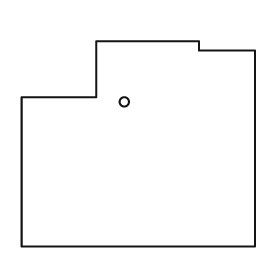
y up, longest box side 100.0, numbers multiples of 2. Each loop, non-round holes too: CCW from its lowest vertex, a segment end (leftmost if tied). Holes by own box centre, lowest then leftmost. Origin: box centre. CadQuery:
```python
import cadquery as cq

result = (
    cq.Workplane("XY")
    .moveTo(-50.0, -44.0)
    .lineTo(50.0, -44.0)
    .lineTo(50.0, 40.0)
    .lineTo(26.0, 40.0)
    .lineTo(26.0, 44.0)
    .lineTo(-18.0, 44.0)
    .lineTo(-18.0, 20.0)
    .lineTo(-50.0, 20.0)
    .close()
    .moveTo(-6.0, 18.0)
    .circle(2.0)
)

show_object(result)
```